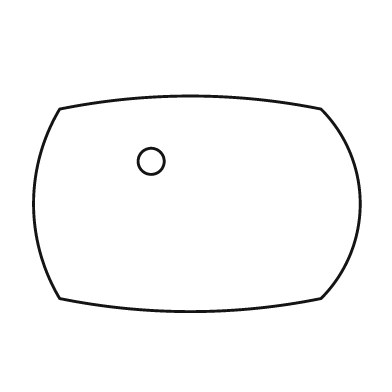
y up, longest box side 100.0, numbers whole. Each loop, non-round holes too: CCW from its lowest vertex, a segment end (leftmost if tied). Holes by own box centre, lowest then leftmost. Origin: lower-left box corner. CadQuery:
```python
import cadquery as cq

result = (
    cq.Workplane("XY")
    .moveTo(8.0, 4.0)
    .threePointArc((48.0, 0.0), (88.0, 4.0))
    .threePointArc((100.0, 33.0), (88.0, 62.0))
    .threePointArc((48.0, 66.0), (8.0, 62.0))
    .threePointArc((0.0, 33.0), (8.0, 4.0))
    .close()
    .moveTo(36.0, 46.0)
    .circle(4.0)
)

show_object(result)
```